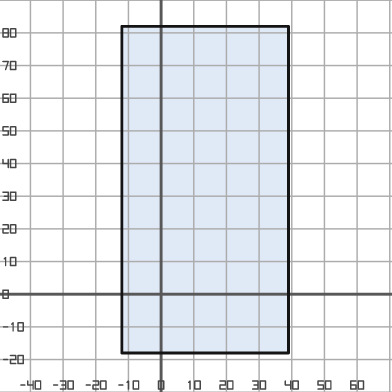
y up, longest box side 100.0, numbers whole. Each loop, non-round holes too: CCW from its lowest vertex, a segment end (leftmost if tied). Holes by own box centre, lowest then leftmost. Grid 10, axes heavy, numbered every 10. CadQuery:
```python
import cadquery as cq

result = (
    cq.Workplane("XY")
    .moveTo(-12.0, -18.0)
    .lineTo(39.0, -18.0)
    .lineTo(39.0, 82.0)
    .lineTo(-12.0, 82.0)
    .close()
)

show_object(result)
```